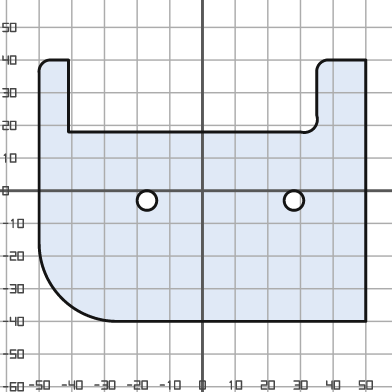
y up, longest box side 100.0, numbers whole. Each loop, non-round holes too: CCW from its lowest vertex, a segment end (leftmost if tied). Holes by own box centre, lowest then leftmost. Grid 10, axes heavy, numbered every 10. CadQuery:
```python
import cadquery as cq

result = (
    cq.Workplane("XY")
    .moveTo(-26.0, -40.0)
    .lineTo(50.0, -40.0)
    .lineTo(50.0, 40.0)
    .lineTo(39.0, 40.0)
    .threePointArc((36.0, 39.0), (35.0, 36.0))
    .lineTo(35.0, 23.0)
    .threePointArc((34.0, 19.0), (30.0, 18.0))
    .lineTo(-41.0, 18.0)
    .lineTo(-41.0, 40.0)
    .lineTo(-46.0, 40.0)
    .threePointArc((-49.0, 39.0), (-50.0, 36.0))
    .lineTo(-50.0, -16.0)
    .threePointArc((-43.0, -33.0), (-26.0, -40.0))
    .close()
    .moveTo(-17.0, -3.0)
    .circle(3.0)
    .moveTo(28.0, -3.0)
    .circle(3.0)
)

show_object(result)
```